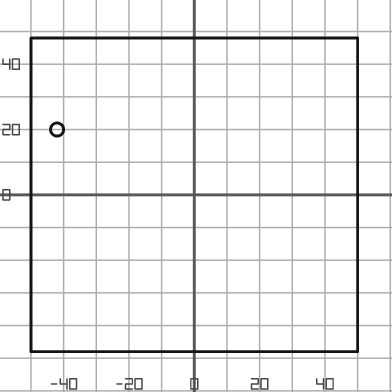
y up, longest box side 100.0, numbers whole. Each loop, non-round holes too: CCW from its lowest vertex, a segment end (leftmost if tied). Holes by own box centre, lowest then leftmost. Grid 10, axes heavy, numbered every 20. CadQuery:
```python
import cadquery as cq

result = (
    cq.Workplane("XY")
    .moveTo(-50.0, -48.0)
    .lineTo(50.0, -48.0)
    .lineTo(50.0, 48.0)
    .lineTo(-50.0, 48.0)
    .close()
    .moveTo(-42.0, 20.0)
    .circle(2.0)
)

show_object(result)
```